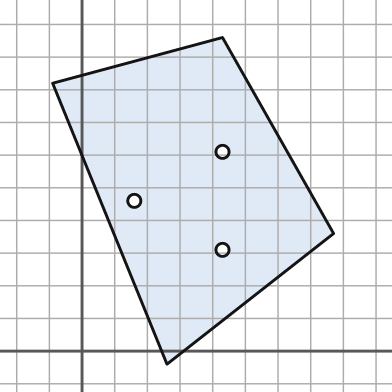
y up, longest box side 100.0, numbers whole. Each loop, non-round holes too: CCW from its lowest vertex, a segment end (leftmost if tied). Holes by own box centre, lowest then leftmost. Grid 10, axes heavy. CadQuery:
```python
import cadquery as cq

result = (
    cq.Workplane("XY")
    .moveTo(26.0, -4.0)
    .lineTo(77.0, 36.0)
    .lineTo(43.0, 96.0)
    .lineTo(-9.0, 82.0)
    .close()
    .moveTo(43.0, 31.0)
    .circle(2.0)
    .moveTo(16.0, 46.0)
    .circle(2.0)
    .moveTo(43.0, 61.0)
    .circle(2.0)
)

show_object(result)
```